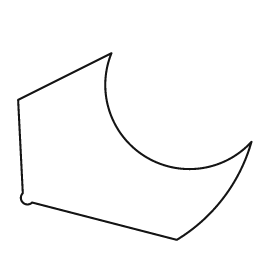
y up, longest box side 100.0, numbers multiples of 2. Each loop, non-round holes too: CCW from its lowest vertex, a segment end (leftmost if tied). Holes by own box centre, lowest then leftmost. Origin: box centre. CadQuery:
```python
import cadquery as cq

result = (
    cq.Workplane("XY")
    .moveTo(18.0, -40.0)
    .threePointArc((38.0, -22.0), (50.0, 2.0))
    .threePointArc((4.0, -4.0), (-10.0, 40.0))
    .lineTo(-50.0, 20.0)
    .lineTo(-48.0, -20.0)
    .threePointArc((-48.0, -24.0), (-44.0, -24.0))
    .close()
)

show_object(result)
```